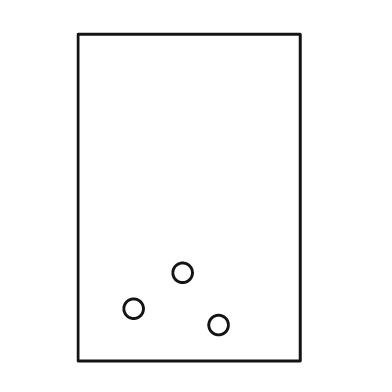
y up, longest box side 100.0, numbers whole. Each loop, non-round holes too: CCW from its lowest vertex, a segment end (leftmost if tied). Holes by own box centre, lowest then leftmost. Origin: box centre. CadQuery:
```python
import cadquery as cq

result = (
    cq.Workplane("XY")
    .moveTo(-34.0, -50.0)
    .lineTo(34.0, -50.0)
    .lineTo(34.0, 50.0)
    .lineTo(-34.0, 50.0)
    .close()
    .moveTo(9.0, -39.0)
    .circle(3.0)
    .moveTo(-17.0, -34.0)
    .circle(3.0)
    .moveTo(-2.0, -23.0)
    .circle(3.0)
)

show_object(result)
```